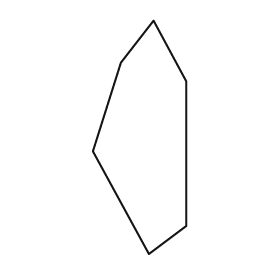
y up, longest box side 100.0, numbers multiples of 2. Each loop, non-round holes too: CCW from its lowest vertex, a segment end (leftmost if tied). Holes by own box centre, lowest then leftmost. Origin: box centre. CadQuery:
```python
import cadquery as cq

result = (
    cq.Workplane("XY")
    .moveTo(4.0, -50.0)
    .lineTo(20.0, -38.0)
    .lineTo(20.0, 24.0)
    .lineTo(6.0, 50.0)
    .lineTo(-8.0, 32.0)
    .lineTo(-20.0, -6.0)
    .close()
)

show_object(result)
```